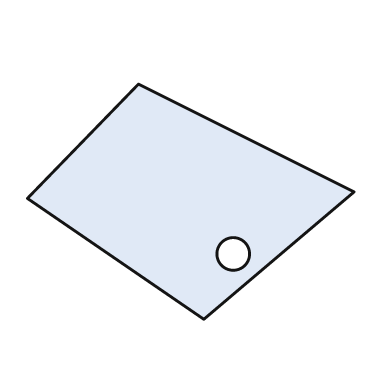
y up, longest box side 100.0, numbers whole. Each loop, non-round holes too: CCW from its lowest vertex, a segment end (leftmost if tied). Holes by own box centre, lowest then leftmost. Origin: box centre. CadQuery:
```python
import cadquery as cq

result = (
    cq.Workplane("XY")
    .moveTo(4.0, -36.0)
    .lineTo(50.0, 3.0)
    .lineTo(-16.0, 36.0)
    .lineTo(-50.0, 1.0)
    .close()
    .moveTo(13.0, -16.0)
    .circle(5.0)
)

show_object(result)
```